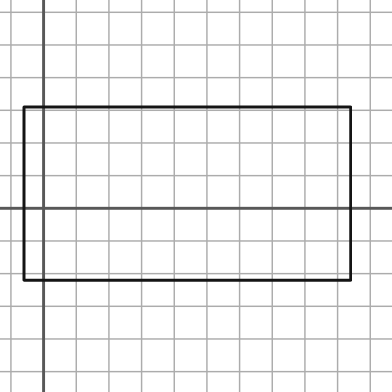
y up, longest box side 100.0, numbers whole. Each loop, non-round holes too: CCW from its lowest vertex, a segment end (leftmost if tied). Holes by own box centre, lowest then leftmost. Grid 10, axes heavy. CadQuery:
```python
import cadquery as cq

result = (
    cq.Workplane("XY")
    .moveTo(-6.0, -22.0)
    .lineTo(94.0, -22.0)
    .lineTo(94.0, 31.0)
    .lineTo(-6.0, 31.0)
    .close()
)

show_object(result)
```